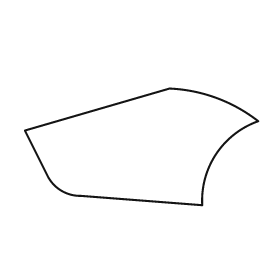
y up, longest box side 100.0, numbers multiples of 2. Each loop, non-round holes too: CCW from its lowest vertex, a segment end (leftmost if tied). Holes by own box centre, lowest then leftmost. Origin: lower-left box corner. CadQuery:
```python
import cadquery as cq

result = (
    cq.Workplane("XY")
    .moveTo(76.0, 0.0)
    .threePointArc((82.0, 22.0), (100.0, 36.0))
    .threePointArc((82.0, 46.0), (62.0, 50.0))
    .lineTo(0.0, 32.0)
    .lineTo(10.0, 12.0)
    .threePointArc((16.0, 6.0), (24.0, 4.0))
    .close()
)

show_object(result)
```